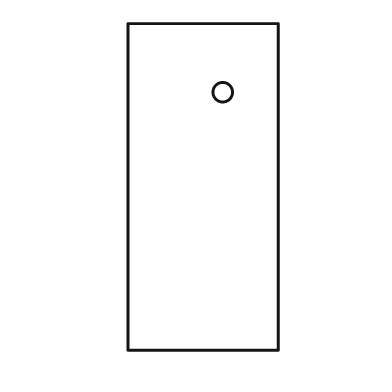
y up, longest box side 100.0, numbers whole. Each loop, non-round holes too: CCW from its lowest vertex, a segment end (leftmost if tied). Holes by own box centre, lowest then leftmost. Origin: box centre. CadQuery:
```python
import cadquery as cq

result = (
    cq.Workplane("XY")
    .moveTo(-23.0, -50.0)
    .lineTo(23.0, -50.0)
    .lineTo(23.0, 50.0)
    .lineTo(-23.0, 50.0)
    .close()
    .moveTo(6.0, 29.0)
    .circle(3.0)
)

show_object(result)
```